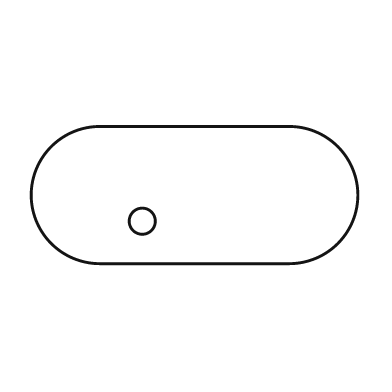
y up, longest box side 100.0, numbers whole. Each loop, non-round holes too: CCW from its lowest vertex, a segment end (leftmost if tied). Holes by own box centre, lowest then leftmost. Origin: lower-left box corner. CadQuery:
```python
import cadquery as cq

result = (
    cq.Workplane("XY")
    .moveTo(21.0, 0.0)
    .lineTo(79.0, 0.0)
    .threePointArc((100.0, 21.0), (79.0, 42.0))
    .lineTo(21.0, 42.0)
    .threePointArc((0.0, 21.0), (21.0, 0.0))
    .close()
    .moveTo(34.0, 13.0)
    .circle(4.0)
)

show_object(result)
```